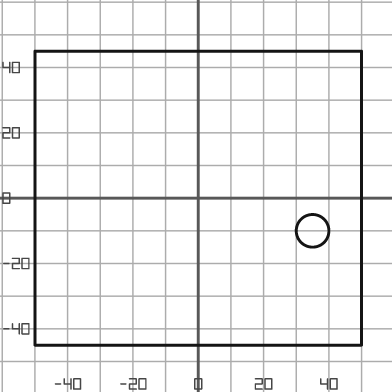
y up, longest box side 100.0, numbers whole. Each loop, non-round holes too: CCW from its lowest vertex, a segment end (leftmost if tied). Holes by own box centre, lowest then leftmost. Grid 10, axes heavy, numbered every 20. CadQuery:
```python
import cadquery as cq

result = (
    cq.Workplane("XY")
    .moveTo(-50.0, -45.0)
    .lineTo(50.0, -45.0)
    .lineTo(50.0, 45.0)
    .lineTo(-50.0, 45.0)
    .close()
    .moveTo(35.0, -10.0)
    .circle(5.0)
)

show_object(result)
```